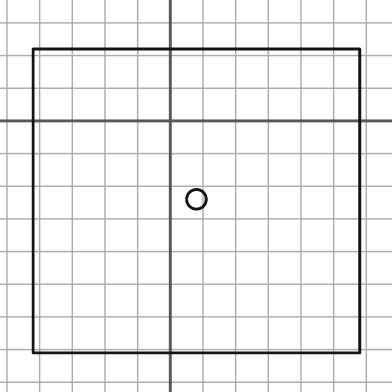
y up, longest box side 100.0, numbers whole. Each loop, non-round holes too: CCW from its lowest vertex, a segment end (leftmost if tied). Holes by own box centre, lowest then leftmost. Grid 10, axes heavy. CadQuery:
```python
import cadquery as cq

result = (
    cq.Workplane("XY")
    .moveTo(-42.0, -71.0)
    .lineTo(58.0, -71.0)
    .lineTo(58.0, 22.0)
    .lineTo(-42.0, 22.0)
    .close()
    .moveTo(8.0, -24.0)
    .circle(3.0)
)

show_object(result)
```